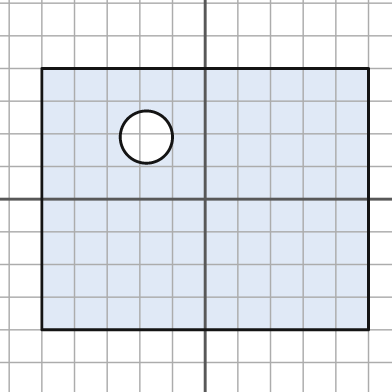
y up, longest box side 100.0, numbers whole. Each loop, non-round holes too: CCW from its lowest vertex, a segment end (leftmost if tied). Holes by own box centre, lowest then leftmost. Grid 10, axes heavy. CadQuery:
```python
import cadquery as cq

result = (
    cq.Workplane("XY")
    .moveTo(-50.0, -40.0)
    .lineTo(50.0, -40.0)
    .lineTo(50.0, 40.0)
    .lineTo(-50.0, 40.0)
    .close()
    .moveTo(-18.0, 19.0)
    .circle(8.0)
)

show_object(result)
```